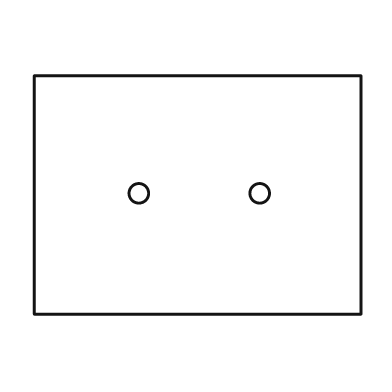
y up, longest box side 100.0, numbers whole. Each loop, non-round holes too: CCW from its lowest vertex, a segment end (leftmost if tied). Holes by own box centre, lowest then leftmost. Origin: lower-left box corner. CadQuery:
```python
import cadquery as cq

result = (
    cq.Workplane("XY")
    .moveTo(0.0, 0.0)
    .lineTo(100.0, 0.0)
    .lineTo(100.0, 73.0)
    .lineTo(0.0, 73.0)
    .close()
    .moveTo(32.0, 37.0)
    .circle(3.0)
    .moveTo(69.0, 37.0)
    .circle(3.0)
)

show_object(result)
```